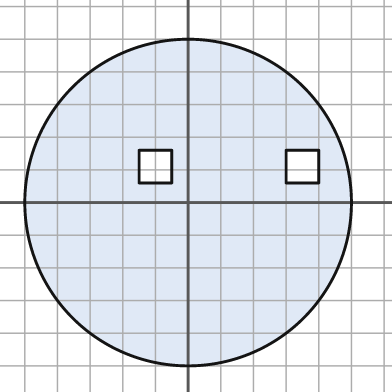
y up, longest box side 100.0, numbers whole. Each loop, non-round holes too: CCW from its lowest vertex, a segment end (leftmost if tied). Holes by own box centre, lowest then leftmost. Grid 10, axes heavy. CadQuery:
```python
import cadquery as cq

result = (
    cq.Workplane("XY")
    .moveTo(0.0, 0.0)
    .circle(50.0)
    .moveTo(-15.0, 6.0)
    .lineTo(-5.0, 6.0)
    .lineTo(-5.0, 16.0)
    .lineTo(-15.0, 16.0)
    .close()
    .moveTo(30.0, 6.0)
    .lineTo(40.0, 6.0)
    .lineTo(40.0, 16.0)
    .lineTo(30.0, 16.0)
    .close()
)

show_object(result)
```